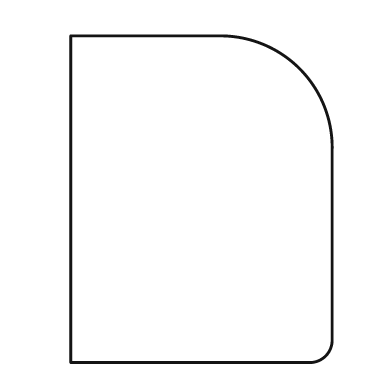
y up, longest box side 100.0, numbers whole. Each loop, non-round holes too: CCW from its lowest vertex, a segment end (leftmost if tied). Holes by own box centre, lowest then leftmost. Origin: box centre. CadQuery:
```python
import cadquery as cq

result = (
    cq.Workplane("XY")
    .moveTo(-40.0, -50.0)
    .lineTo(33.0, -50.0)
    .threePointArc((38.0, -48.0), (40.0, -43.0))
    .lineTo(40.0, 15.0)
    .threePointArc((30.0, 40.0), (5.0, 50.0))
    .lineTo(-40.0, 50.0)
    .close()
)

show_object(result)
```